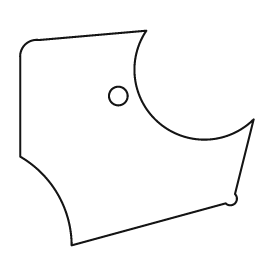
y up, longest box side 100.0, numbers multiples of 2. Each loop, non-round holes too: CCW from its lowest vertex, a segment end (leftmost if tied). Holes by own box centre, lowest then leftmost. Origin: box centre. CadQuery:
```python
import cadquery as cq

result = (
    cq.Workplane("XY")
    .moveTo(-28.0, -46.0)
    .lineTo(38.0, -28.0)
    .threePointArc((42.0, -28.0), (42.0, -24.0))
    .lineTo(50.0, 8.0)
    .threePointArc((10.0, 6.0), (4.0, 46.0))
    .lineTo(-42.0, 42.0)
    .threePointArc((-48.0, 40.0), (-50.0, 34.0))
    .lineTo(-50.0, -8.0)
    .threePointArc((-34.0, -24.0), (-28.0, -46.0))
    .close()
    .moveTo(-8.0, 18.0)
    .circle(4.0)
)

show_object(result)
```